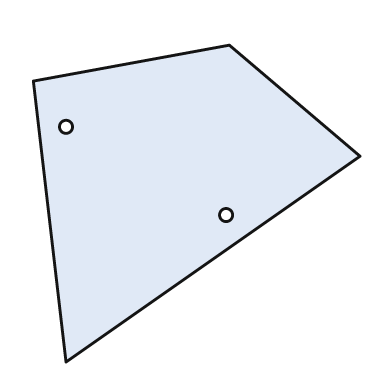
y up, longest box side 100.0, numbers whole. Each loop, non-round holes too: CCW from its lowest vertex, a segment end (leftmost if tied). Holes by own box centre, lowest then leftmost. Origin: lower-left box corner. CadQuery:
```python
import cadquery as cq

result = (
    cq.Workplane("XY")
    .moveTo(10.0, 0.0)
    .lineTo(100.0, 63.0)
    .lineTo(60.0, 97.0)
    .lineTo(0.0, 86.0)
    .close()
    .moveTo(59.0, 45.0)
    .circle(2.0)
    .moveTo(10.0, 72.0)
    .circle(2.0)
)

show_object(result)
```